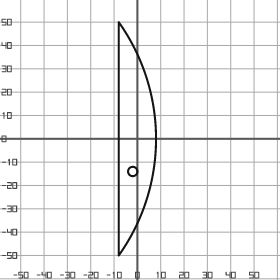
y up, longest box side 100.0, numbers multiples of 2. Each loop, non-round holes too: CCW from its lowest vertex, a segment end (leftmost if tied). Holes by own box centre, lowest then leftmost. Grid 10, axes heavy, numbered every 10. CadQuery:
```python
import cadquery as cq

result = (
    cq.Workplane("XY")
    .moveTo(-8.0, -50.0)
    .threePointArc((8.0, 0.0), (-8.0, 50.0))
    .close()
    .moveTo(-2.0, -14.0)
    .circle(2.0)
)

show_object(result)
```